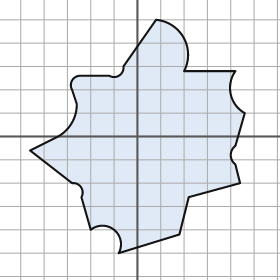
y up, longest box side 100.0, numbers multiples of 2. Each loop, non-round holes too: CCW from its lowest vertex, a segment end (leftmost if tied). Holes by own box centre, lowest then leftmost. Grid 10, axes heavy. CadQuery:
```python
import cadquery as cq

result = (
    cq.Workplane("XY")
    .moveTo(-8.0, -50.0)
    .lineTo(18.0, -42.0)
    .lineTo(22.0, -26.0)
    .lineTo(44.0, -20.0)
    .lineTo(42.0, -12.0)
    .threePointArc((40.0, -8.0), (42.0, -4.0))
    .lineTo(46.0, 10.0)
    .threePointArc((40.0, 18.0), (42.0, 28.0))
    .lineTo(20.0, 28.0)
    .threePointArc((20.0, 42.0), (8.0, 50.0))
    .lineTo(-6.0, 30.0)
    .threePointArc((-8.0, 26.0), (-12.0, 26.0))
    .lineTo(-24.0, 26.0)
    .threePointArc((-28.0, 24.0), (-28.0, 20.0))
    .lineTo(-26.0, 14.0)
    .threePointArc((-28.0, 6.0), (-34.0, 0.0))
    .lineTo(-46.0, -6.0)
    .lineTo(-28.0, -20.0)
    .threePointArc((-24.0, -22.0), (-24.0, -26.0))
    .lineTo(-20.0, -40.0)
    .threePointArc((-10.0, -40.0), (-8.0, -50.0))
    .close()
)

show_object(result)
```